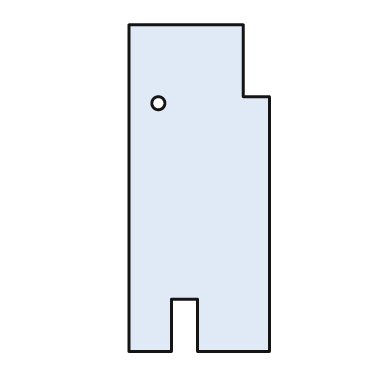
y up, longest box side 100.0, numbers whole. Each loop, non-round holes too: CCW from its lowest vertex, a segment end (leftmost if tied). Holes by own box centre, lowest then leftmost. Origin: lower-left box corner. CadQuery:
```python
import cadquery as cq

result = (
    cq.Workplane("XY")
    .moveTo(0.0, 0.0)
    .lineTo(13.0, 0.0)
    .lineTo(13.0, 16.0)
    .lineTo(21.0, 16.0)
    .lineTo(21.0, 0.0)
    .lineTo(43.0, 0.0)
    .lineTo(43.0, 78.0)
    .lineTo(35.0, 78.0)
    .lineTo(35.0, 100.0)
    .lineTo(0.0, 100.0)
    .close()
    .moveTo(9.0, 76.0)
    .circle(2.0)
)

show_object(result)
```